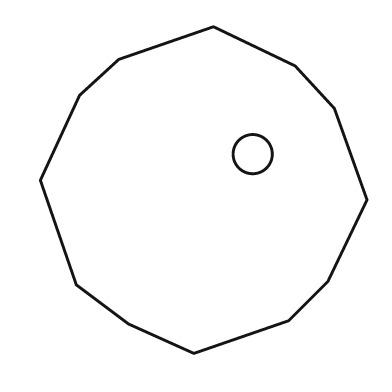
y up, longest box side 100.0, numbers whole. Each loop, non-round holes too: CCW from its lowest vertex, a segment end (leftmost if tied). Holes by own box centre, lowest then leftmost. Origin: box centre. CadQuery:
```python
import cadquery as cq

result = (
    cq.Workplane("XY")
    .moveTo(-3.0, -50.0)
    .lineTo(26.0, -40.0)
    .lineTo(38.0, -28.0)
    .lineTo(50.0, -3.0)
    .lineTo(40.0, 25.0)
    .lineTo(28.0, 38.0)
    .lineTo(3.0, 50.0)
    .lineTo(-26.0, 40.0)
    .lineTo(-38.0, 29.0)
    .lineTo(-50.0, 3.0)
    .lineTo(-39.0, -29.0)
    .lineTo(-23.0, -41.0)
    .close()
    .moveTo(15.0, 11.0)
    .circle(6.0)
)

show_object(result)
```